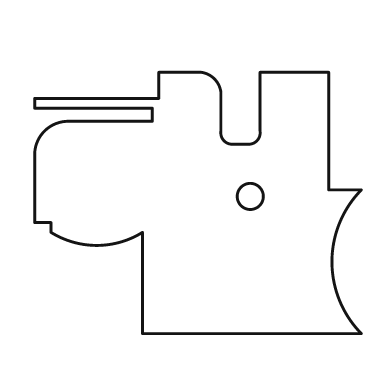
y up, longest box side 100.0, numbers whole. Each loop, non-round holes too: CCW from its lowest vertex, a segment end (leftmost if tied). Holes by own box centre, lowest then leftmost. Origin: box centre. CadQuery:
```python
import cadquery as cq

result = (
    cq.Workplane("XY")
    .moveTo(-17.0, -40.0)
    .lineTo(50.0, -40.0)
    .threePointArc((41.0, -18.0), (50.0, 4.0))
    .lineTo(40.0, 4.0)
    .lineTo(40.0, 40.0)
    .lineTo(19.0, 40.0)
    .lineTo(19.0, 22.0)
    .threePointArc((18.0, 19.0), (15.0, 18.0))
    .lineTo(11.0, 18.0)
    .threePointArc((8.0, 19.0), (7.0, 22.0))
    .lineTo(7.0, 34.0)
    .threePointArc((5.0, 38.0), (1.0, 40.0))
    .lineTo(-12.0, 40.0)
    .lineTo(-12.0, 32.0)
    .lineTo(-50.0, 32.0)
    .lineTo(-50.0, 29.0)
    .lineTo(-14.0, 29.0)
    .lineTo(-14.0, 25.0)
    .lineTo(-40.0, 25.0)
    .threePointArc((-47.0, 22.0), (-50.0, 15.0))
    .lineTo(-50.0, -6.0)
    .lineTo(-45.0, -6.0)
    .lineTo(-45.0, -9.0)
    .threePointArc((-31.0, -13.0), (-17.0, -9.0))
    .close()
    .moveTo(16.0, 2.0)
    .circle(4.0)
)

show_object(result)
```